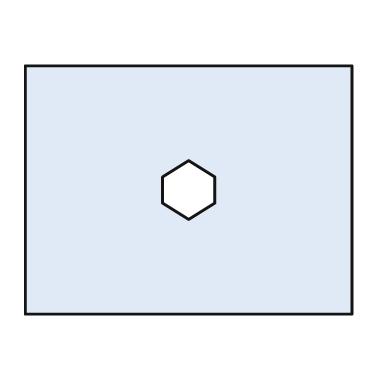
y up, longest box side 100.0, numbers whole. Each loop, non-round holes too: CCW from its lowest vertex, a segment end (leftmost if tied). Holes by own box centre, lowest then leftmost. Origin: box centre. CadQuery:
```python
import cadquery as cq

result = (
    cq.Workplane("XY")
    .moveTo(-50.0, -38.0)
    .lineTo(50.0, -38.0)
    .lineTo(50.0, 38.0)
    .lineTo(-50.0, 38.0)
    .close()
    .moveTo(0.0, -9.0)
    .lineTo(8.0, -4.0)
    .lineTo(8.0, 4.0)
    .lineTo(0.0, 9.0)
    .lineTo(-8.0, 4.0)
    .lineTo(-8.0, -4.0)
    .close()
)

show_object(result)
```